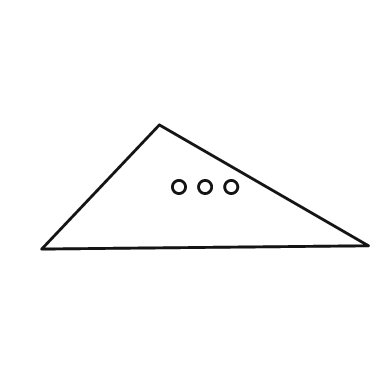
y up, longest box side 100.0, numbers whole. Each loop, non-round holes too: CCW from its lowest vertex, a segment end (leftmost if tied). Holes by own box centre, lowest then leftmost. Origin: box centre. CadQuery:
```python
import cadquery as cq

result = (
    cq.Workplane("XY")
    .moveTo(-50.0, -19.0)
    .lineTo(50.0, -18.0)
    .lineTo(-14.0, 19.0)
    .close()
    .moveTo(-8.0, 0.0)
    .circle(2.0)
    .moveTo(0.0, 0.0)
    .circle(2.0)
    .moveTo(8.0, 0.0)
    .circle(2.0)
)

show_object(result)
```